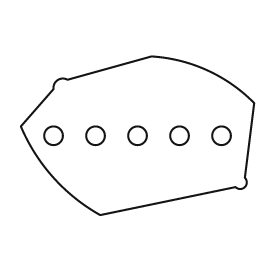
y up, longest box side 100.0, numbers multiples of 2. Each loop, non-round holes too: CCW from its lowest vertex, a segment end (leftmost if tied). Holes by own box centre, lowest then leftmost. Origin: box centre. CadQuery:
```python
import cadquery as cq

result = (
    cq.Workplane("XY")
    .moveTo(-16.0, -34.0)
    .lineTo(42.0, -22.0)
    .threePointArc((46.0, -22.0), (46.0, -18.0))
    .lineTo(50.0, 14.0)
    .threePointArc((30.0, 28.0), (6.0, 34.0))
    .lineTo(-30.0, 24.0)
    .threePointArc((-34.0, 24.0), (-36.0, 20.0))
    .lineTo(-50.0, 4.0)
    .threePointArc((-36.0, -18.0), (-16.0, -34.0))
    .close()
    .moveTo(-36.0, 0.0)
    .circle(4.0)
    .moveTo(-18.0, 0.0)
    .circle(4.0)
    .moveTo(0.0, 0.0)
    .circle(4.0)
    .moveTo(18.0, 0.0)
    .circle(4.0)
    .moveTo(36.0, 0.0)
    .circle(4.0)
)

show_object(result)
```